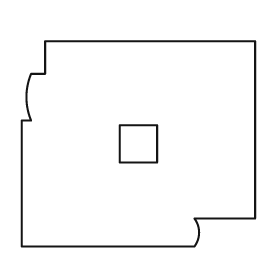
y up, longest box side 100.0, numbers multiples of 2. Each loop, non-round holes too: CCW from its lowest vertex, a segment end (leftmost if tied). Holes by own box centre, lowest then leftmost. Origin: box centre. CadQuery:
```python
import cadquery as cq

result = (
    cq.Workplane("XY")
    .moveTo(-50.0, -44.0)
    .lineTo(24.0, -44.0)
    .threePointArc((26.0, -38.0), (24.0, -32.0))
    .lineTo(50.0, -32.0)
    .lineTo(50.0, 44.0)
    .lineTo(-40.0, 44.0)
    .lineTo(-40.0, 30.0)
    .lineTo(-46.0, 30.0)
    .threePointArc((-48.0, 20.0), (-46.0, 10.0))
    .lineTo(-50.0, 10.0)
    .close()
    .moveTo(-8.0, -8.0)
    .lineTo(8.0, -8.0)
    .lineTo(8.0, 8.0)
    .lineTo(-8.0, 8.0)
    .close()
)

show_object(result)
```